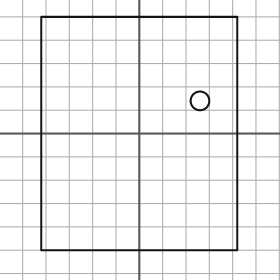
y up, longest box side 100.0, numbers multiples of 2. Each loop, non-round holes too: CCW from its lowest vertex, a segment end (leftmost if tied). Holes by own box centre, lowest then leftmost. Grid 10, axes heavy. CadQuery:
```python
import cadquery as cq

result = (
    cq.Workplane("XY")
    .moveTo(-42.0, -50.0)
    .lineTo(42.0, -50.0)
    .lineTo(42.0, 50.0)
    .lineTo(-42.0, 50.0)
    .close()
    .moveTo(26.0, 14.0)
    .circle(4.0)
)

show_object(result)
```